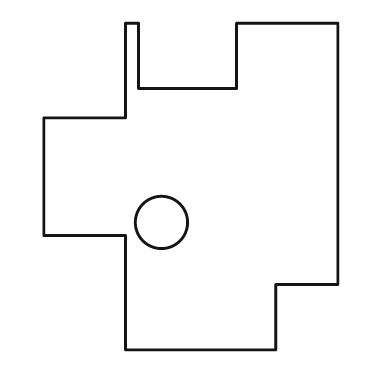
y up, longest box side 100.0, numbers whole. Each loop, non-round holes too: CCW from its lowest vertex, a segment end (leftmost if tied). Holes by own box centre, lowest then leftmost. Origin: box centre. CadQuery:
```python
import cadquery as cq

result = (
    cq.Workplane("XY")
    .moveTo(-20.0, -50.0)
    .lineTo(26.0, -50.0)
    .lineTo(26.0, -30.0)
    .lineTo(45.0, -30.0)
    .lineTo(45.0, 50.0)
    .lineTo(14.0, 50.0)
    .lineTo(14.0, 30.0)
    .lineTo(-16.0, 30.0)
    .lineTo(-16.0, 50.0)
    .lineTo(-20.0, 50.0)
    .lineTo(-20.0, 21.0)
    .lineTo(-45.0, 21.0)
    .lineTo(-45.0, -15.0)
    .lineTo(-20.0, -15.0)
    .close()
    .moveTo(-9.0, -11.0)
    .circle(8.0)
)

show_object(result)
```